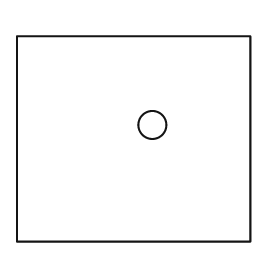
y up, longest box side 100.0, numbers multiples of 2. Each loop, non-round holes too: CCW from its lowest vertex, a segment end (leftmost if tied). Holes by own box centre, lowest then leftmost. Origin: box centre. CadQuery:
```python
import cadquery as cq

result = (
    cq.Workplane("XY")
    .moveTo(-50.0, -44.0)
    .lineTo(50.0, -44.0)
    .lineTo(50.0, 44.0)
    .lineTo(-50.0, 44.0)
    .close()
    .moveTo(8.0, 6.0)
    .circle(6.0)
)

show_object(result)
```